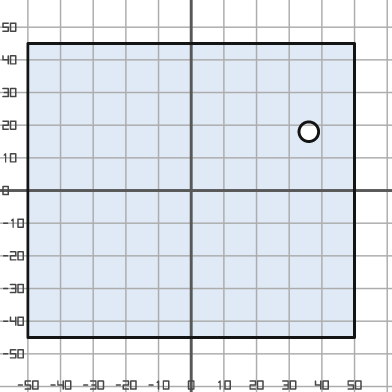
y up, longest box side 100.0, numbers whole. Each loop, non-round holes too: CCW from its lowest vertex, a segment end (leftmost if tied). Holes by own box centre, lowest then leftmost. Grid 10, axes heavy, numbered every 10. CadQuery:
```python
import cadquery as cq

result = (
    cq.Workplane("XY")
    .moveTo(-50.0, -45.0)
    .lineTo(50.0, -45.0)
    .lineTo(50.0, 45.0)
    .lineTo(-50.0, 45.0)
    .close()
    .moveTo(36.0, 18.0)
    .circle(3.0)
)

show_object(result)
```